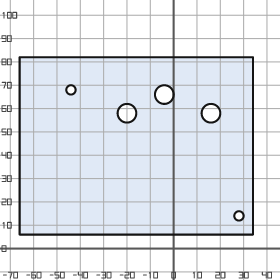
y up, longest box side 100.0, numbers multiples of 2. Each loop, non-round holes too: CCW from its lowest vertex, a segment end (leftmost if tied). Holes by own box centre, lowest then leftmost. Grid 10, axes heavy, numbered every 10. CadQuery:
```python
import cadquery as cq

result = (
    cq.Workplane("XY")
    .moveTo(-66.0, 6.0)
    .lineTo(34.0, 6.0)
    .lineTo(34.0, 82.0)
    .lineTo(-66.0, 82.0)
    .close()
    .moveTo(28.0, 14.0)
    .circle(2.0)
    .moveTo(-20.0, 58.0)
    .circle(4.0)
    .moveTo(16.0, 58.0)
    .circle(4.0)
    .moveTo(-4.0, 66.0)
    .circle(4.0)
    .moveTo(-44.0, 68.0)
    .circle(2.0)
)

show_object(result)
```